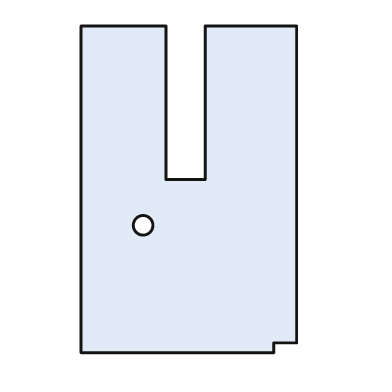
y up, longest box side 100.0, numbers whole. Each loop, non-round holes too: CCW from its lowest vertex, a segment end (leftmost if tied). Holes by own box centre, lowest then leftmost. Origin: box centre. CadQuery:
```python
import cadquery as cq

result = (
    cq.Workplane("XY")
    .moveTo(-33.0, -50.0)
    .lineTo(26.0, -50.0)
    .lineTo(26.0, -47.0)
    .lineTo(33.0, -47.0)
    .lineTo(33.0, 50.0)
    .lineTo(5.0, 50.0)
    .lineTo(5.0, 3.0)
    .lineTo(-7.0, 3.0)
    .lineTo(-7.0, 50.0)
    .lineTo(-33.0, 50.0)
    .close()
    .moveTo(-14.0, -11.0)
    .circle(3.0)
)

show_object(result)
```